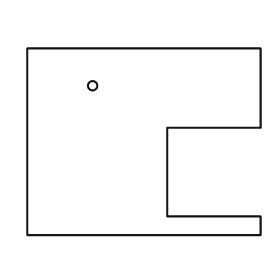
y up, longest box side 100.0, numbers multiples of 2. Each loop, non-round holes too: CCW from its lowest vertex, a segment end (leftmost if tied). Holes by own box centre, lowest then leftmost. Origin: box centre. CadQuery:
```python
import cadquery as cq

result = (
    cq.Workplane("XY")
    .moveTo(-50.0, -40.0)
    .lineTo(50.0, -40.0)
    .lineTo(50.0, -32.0)
    .lineTo(10.0, -32.0)
    .lineTo(10.0, 6.0)
    .lineTo(50.0, 6.0)
    .lineTo(50.0, 40.0)
    .lineTo(-50.0, 40.0)
    .close()
    .moveTo(-22.0, 24.0)
    .circle(2.0)
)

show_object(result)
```